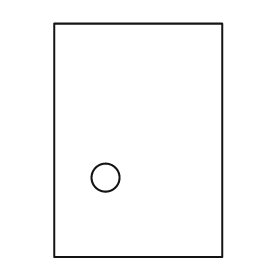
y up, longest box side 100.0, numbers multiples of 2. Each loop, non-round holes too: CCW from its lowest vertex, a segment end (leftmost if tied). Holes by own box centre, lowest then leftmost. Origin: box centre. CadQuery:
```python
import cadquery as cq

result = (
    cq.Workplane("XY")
    .moveTo(-36.0, -50.0)
    .lineTo(36.0, -50.0)
    .lineTo(36.0, 50.0)
    .lineTo(-36.0, 50.0)
    .close()
    .moveTo(-14.0, -16.0)
    .circle(6.0)
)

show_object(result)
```